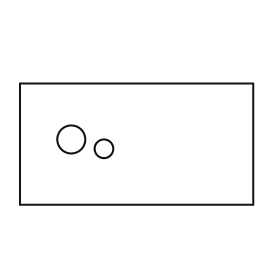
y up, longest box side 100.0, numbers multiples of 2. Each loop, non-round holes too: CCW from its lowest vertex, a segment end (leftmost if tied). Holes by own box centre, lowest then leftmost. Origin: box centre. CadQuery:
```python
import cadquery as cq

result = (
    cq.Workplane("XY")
    .moveTo(-50.0, -26.0)
    .lineTo(50.0, -26.0)
    .lineTo(50.0, 26.0)
    .lineTo(-50.0, 26.0)
    .close()
    .moveTo(-14.0, -2.0)
    .circle(4.0)
    .moveTo(-28.0, 2.0)
    .circle(6.0)
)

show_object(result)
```